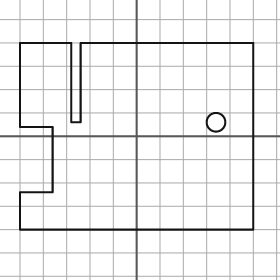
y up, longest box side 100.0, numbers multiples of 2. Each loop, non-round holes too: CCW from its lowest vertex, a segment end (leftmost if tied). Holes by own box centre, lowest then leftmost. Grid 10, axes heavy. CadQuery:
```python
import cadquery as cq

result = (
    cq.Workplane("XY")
    .moveTo(-50.0, -40.0)
    .lineTo(50.0, -40.0)
    .lineTo(50.0, 40.0)
    .lineTo(-24.0, 40.0)
    .lineTo(-24.0, 6.0)
    .lineTo(-28.0, 6.0)
    .lineTo(-28.0, 40.0)
    .lineTo(-50.0, 40.0)
    .lineTo(-50.0, 4.0)
    .lineTo(-36.0, 4.0)
    .lineTo(-36.0, -24.0)
    .lineTo(-50.0, -24.0)
    .close()
    .moveTo(34.0, 6.0)
    .circle(4.0)
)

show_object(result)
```